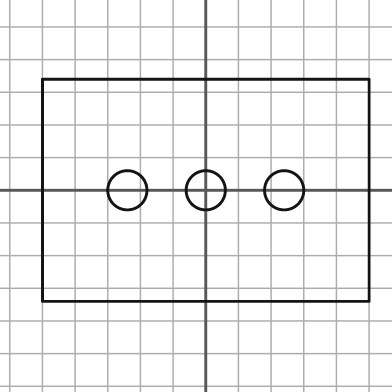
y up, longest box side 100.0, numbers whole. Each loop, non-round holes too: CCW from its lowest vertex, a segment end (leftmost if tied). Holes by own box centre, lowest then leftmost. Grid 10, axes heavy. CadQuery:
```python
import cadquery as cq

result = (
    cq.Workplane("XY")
    .moveTo(-50.0, -34.0)
    .lineTo(50.0, -34.0)
    .lineTo(50.0, 34.0)
    .lineTo(-50.0, 34.0)
    .close()
    .moveTo(-24.0, 0.0)
    .circle(6.0)
    .moveTo(0.0, 0.0)
    .circle(6.0)
    .moveTo(24.0, 0.0)
    .circle(6.0)
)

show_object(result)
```